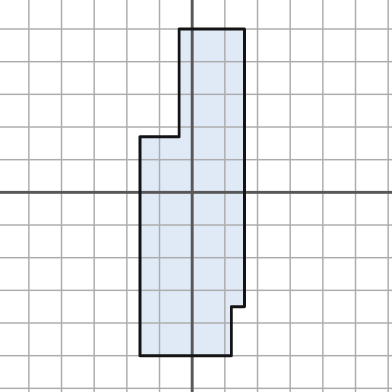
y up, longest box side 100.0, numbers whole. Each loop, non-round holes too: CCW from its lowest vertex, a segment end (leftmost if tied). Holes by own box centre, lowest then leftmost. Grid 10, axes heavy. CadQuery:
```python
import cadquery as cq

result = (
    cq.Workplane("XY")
    .moveTo(-16.0, -50.0)
    .lineTo(12.0, -50.0)
    .lineTo(12.0, -35.0)
    .lineTo(16.0, -35.0)
    .lineTo(16.0, 50.0)
    .lineTo(-4.0, 50.0)
    .lineTo(-4.0, 17.0)
    .lineTo(-16.0, 17.0)
    .close()
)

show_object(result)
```